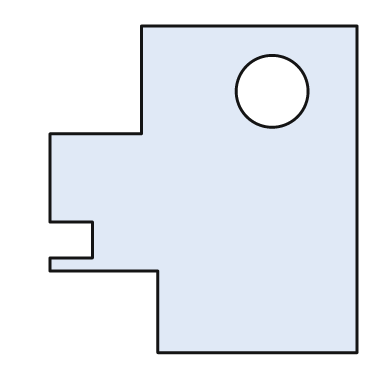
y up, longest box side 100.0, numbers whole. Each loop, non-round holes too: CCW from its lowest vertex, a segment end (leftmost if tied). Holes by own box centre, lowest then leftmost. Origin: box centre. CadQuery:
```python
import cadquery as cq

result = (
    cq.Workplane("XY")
    .moveTo(-14.0, -50.0)
    .lineTo(47.0, -50.0)
    .lineTo(47.0, 50.0)
    .lineTo(-19.0, 50.0)
    .lineTo(-19.0, 17.0)
    .lineTo(-47.0, 17.0)
    .lineTo(-47.0, -10.0)
    .lineTo(-34.0, -10.0)
    .lineTo(-34.0, -21.0)
    .lineTo(-47.0, -21.0)
    .lineTo(-47.0, -25.0)
    .lineTo(-14.0, -25.0)
    .close()
    .moveTo(21.0, 30.0)
    .circle(11.0)
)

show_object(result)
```